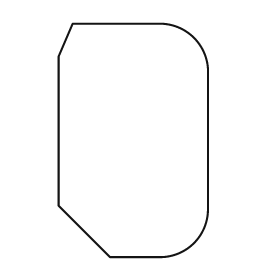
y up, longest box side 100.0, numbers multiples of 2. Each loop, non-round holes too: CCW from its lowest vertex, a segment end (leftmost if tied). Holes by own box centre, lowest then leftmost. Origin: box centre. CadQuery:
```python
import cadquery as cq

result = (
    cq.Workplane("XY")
    .moveTo(-10.0, -50.0)
    .lineTo(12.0, -50.0)
    .threePointArc((26.0, -44.0), (32.0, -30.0))
    .lineTo(32.0, 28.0)
    .threePointArc((26.0, 44.0), (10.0, 50.0))
    .lineTo(-26.0, 50.0)
    .lineTo(-32.0, 36.0)
    .lineTo(-32.0, -28.0)
    .close()
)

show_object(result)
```